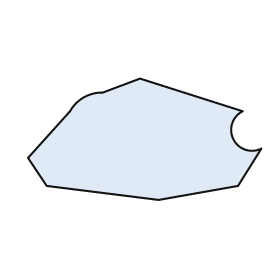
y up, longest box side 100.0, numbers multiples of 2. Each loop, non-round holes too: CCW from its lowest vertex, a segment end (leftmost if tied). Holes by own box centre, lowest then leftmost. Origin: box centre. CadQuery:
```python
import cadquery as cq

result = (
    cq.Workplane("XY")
    .moveTo(6.0, -26.0)
    .lineTo(40.0, -20.0)
    .lineTo(50.0, -4.0)
    .threePointArc((38.0, 0.0), (42.0, 12.0))
    .lineTo(-2.0, 26.0)
    .lineTo(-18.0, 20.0)
    .threePointArc((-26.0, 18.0), (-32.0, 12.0))
    .lineTo(-50.0, -8.0)
    .lineTo(-42.0, -20.0)
    .close()
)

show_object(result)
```